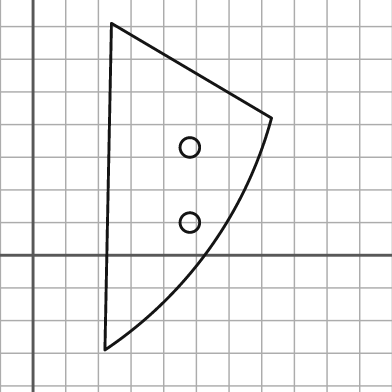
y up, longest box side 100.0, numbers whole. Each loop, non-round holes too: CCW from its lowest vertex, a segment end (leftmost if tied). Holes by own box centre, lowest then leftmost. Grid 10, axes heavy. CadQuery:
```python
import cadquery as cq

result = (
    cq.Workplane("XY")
    .moveTo(22.0, -29.0)
    .threePointArc((54.0, 2.0), (73.0, 42.0))
    .lineTo(24.0, 71.0)
    .close()
    .moveTo(48.0, 10.0)
    .circle(3.0)
    .moveTo(48.0, 33.0)
    .circle(3.0)
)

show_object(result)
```